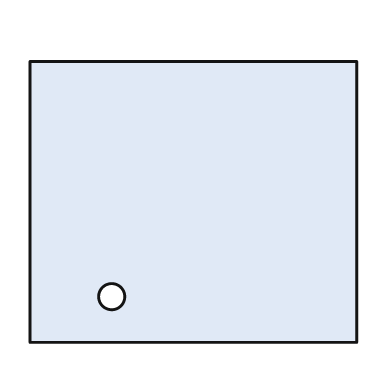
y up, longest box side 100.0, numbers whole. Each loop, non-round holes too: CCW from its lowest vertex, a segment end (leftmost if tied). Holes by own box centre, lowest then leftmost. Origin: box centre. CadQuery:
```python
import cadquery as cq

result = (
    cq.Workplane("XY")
    .moveTo(-50.0, -43.0)
    .lineTo(50.0, -43.0)
    .lineTo(50.0, 43.0)
    .lineTo(-50.0, 43.0)
    .close()
    .moveTo(-25.0, -29.0)
    .circle(4.0)
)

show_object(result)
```